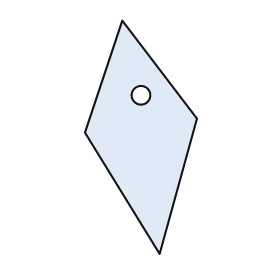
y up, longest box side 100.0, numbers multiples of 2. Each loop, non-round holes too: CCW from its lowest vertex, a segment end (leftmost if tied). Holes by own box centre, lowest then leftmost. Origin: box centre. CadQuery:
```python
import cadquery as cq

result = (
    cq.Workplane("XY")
    .moveTo(8.0, -50.0)
    .lineTo(24.0, 8.0)
    .lineTo(-8.0, 50.0)
    .lineTo(-24.0, 2.0)
    .close()
    .moveTo(0.0, 18.0)
    .circle(4.0)
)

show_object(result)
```